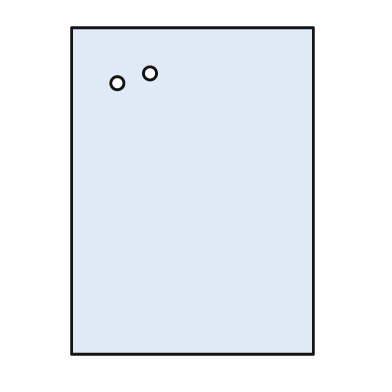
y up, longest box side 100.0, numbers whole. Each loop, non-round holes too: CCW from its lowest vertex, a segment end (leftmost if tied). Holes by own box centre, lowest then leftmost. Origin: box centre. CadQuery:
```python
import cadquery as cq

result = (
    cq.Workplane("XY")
    .moveTo(-37.0, -50.0)
    .lineTo(37.0, -50.0)
    .lineTo(37.0, 50.0)
    .lineTo(-37.0, 50.0)
    .close()
    .moveTo(-23.0, 33.0)
    .circle(2.0)
    .moveTo(-13.0, 36.0)
    .circle(2.0)
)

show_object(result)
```